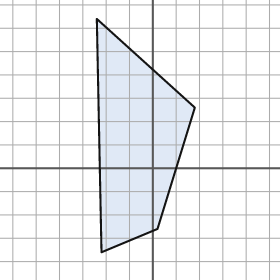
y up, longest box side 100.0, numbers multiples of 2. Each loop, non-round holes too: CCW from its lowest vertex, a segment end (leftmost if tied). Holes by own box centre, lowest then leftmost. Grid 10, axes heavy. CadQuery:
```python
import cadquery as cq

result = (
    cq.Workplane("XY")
    .moveTo(-22.0, -36.0)
    .lineTo(2.0, -26.0)
    .lineTo(18.0, 26.0)
    .lineTo(-24.0, 64.0)
    .close()
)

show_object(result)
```